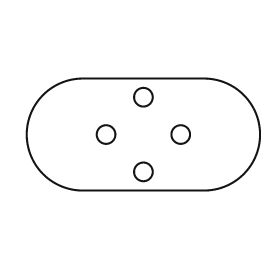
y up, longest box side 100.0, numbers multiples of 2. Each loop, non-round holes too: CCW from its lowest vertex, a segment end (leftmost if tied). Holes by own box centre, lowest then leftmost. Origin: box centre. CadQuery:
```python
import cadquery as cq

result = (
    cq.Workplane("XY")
    .moveTo(-26.0, -24.0)
    .lineTo(26.0, -24.0)
    .threePointArc((50.0, 0.0), (26.0, 24.0))
    .lineTo(-26.0, 24.0)
    .threePointArc((-50.0, 0.0), (-26.0, -24.0))
    .close()
    .moveTo(0.0, -16.0)
    .circle(4.0)
    .moveTo(-16.0, 0.0)
    .circle(4.0)
    .moveTo(16.0, 0.0)
    .circle(4.0)
    .moveTo(0.0, 16.0)
    .circle(4.0)
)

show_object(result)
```